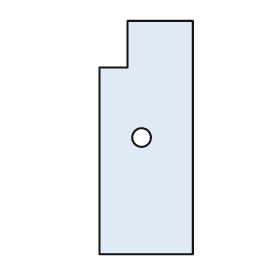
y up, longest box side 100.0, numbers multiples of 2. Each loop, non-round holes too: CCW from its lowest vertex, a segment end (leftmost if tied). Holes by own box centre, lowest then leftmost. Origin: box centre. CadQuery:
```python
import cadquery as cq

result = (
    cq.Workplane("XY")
    .moveTo(-20.0, -50.0)
    .lineTo(20.0, -50.0)
    .lineTo(20.0, 50.0)
    .lineTo(-8.0, 50.0)
    .lineTo(-8.0, 30.0)
    .lineTo(-20.0, 30.0)
    .close()
    .moveTo(-2.0, 0.0)
    .circle(4.0)
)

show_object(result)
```